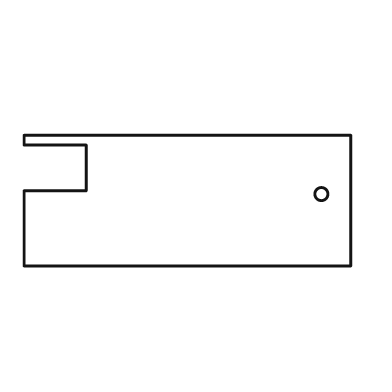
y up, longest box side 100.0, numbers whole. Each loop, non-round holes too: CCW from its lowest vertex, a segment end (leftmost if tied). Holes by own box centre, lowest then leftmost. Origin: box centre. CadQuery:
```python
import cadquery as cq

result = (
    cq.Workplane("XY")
    .moveTo(-50.0, -20.0)
    .lineTo(50.0, -20.0)
    .lineTo(50.0, 20.0)
    .lineTo(-50.0, 20.0)
    .lineTo(-50.0, 17.0)
    .lineTo(-31.0, 17.0)
    .lineTo(-31.0, 3.0)
    .lineTo(-50.0, 3.0)
    .close()
    .moveTo(41.0, 2.0)
    .circle(2.0)
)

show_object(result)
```